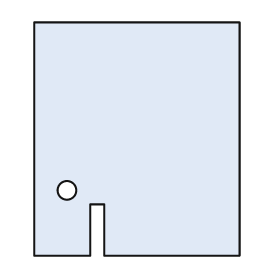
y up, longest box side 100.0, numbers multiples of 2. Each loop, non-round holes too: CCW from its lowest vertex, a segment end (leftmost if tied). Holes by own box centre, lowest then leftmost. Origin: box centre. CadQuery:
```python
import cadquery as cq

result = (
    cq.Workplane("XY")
    .moveTo(-44.0, -50.0)
    .lineTo(-20.0, -50.0)
    .lineTo(-20.0, -28.0)
    .lineTo(-14.0, -28.0)
    .lineTo(-14.0, -50.0)
    .lineTo(44.0, -50.0)
    .lineTo(44.0, 50.0)
    .lineTo(-44.0, 50.0)
    .close()
    .moveTo(-30.0, -22.0)
    .circle(4.0)
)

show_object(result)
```